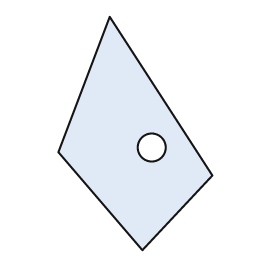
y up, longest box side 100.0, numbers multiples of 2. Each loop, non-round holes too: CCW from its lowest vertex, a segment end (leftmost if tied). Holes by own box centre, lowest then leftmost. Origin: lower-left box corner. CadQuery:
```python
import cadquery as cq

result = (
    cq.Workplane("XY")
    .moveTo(36.0, 0.0)
    .lineTo(66.0, 32.0)
    .lineTo(22.0, 100.0)
    .lineTo(0.0, 42.0)
    .close()
    .moveTo(40.0, 44.0)
    .circle(6.0)
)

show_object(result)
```